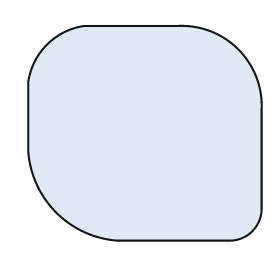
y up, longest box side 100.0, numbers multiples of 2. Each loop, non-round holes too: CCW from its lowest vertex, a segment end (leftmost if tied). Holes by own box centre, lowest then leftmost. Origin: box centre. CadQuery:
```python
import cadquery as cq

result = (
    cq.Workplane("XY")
    .moveTo(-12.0, -46.0)
    .lineTo(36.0, -46.0)
    .threePointArc((46.0, -42.0), (50.0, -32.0))
    .lineTo(50.0, 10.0)
    .threePointArc((40.0, 36.0), (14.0, 46.0))
    .lineTo(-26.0, 46.0)
    .threePointArc((-42.0, 38.0), (-50.0, 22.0))
    .lineTo(-50.0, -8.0)
    .threePointArc((-38.0, -34.0), (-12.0, -46.0))
    .close()
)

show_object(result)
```